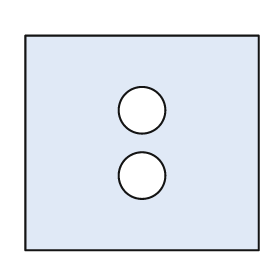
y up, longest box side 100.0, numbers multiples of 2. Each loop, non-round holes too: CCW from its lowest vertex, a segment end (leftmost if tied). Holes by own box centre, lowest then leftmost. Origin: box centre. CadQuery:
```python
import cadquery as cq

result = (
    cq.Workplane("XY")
    .moveTo(-50.0, -46.0)
    .lineTo(50.0, -46.0)
    .lineTo(50.0, 46.0)
    .lineTo(-50.0, 46.0)
    .close()
    .moveTo(0.0, -14.0)
    .circle(10.0)
    .moveTo(0.0, 14.0)
    .circle(10.0)
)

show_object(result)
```